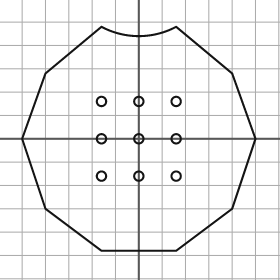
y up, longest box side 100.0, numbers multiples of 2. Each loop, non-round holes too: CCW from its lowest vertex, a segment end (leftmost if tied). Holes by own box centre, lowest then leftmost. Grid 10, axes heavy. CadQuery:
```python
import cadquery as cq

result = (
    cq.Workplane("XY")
    .moveTo(-16.0, -48.0)
    .lineTo(16.0, -48.0)
    .lineTo(40.0, -30.0)
    .lineTo(50.0, 0.0)
    .lineTo(40.0, 28.0)
    .lineTo(16.0, 48.0)
    .threePointArc((0.0, 44.0), (-16.0, 48.0))
    .lineTo(-40.0, 28.0)
    .lineTo(-50.0, 0.0)
    .lineTo(-40.0, -30.0)
    .close()
    .moveTo(-16.0, -16.0)
    .circle(2.0)
    .moveTo(0.0, -16.0)
    .circle(2.0)
    .moveTo(16.0, -16.0)
    .circle(2.0)
    .moveTo(-16.0, 0.0)
    .circle(2.0)
    .moveTo(0.0, 0.0)
    .circle(2.0)
    .moveTo(16.0, 0.0)
    .circle(2.0)
    .moveTo(-16.0, 16.0)
    .circle(2.0)
    .moveTo(0.0, 16.0)
    .circle(2.0)
    .moveTo(16.0, 16.0)
    .circle(2.0)
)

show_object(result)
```